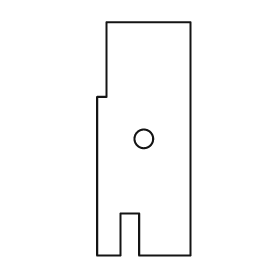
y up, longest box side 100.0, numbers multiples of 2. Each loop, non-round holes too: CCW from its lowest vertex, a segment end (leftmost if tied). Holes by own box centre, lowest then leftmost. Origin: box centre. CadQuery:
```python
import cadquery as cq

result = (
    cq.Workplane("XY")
    .moveTo(-20.0, -50.0)
    .lineTo(-10.0, -50.0)
    .lineTo(-10.0, -32.0)
    .lineTo(-2.0, -32.0)
    .lineTo(-2.0, -50.0)
    .lineTo(20.0, -50.0)
    .lineTo(20.0, 50.0)
    .lineTo(-16.0, 50.0)
    .lineTo(-16.0, 18.0)
    .lineTo(-20.0, 18.0)
    .close()
    .moveTo(0.0, 0.0)
    .circle(4.0)
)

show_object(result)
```